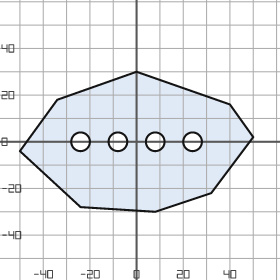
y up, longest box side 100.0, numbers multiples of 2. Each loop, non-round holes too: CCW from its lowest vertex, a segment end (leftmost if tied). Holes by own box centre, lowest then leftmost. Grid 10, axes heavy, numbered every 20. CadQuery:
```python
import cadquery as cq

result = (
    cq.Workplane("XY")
    .moveTo(8.0, -30.0)
    .lineTo(32.0, -22.0)
    .lineTo(50.0, 2.0)
    .lineTo(40.0, 16.0)
    .lineTo(0.0, 30.0)
    .lineTo(-34.0, 18.0)
    .lineTo(-50.0, -4.0)
    .lineTo(-24.0, -28.0)
    .close()
    .moveTo(-24.0, 0.0)
    .circle(4.0)
    .moveTo(-8.0, 0.0)
    .circle(4.0)
    .moveTo(8.0, 0.0)
    .circle(4.0)
    .moveTo(24.0, 0.0)
    .circle(4.0)
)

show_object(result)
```